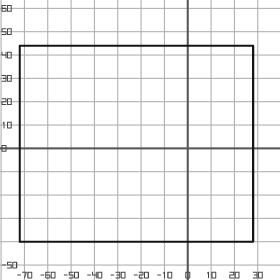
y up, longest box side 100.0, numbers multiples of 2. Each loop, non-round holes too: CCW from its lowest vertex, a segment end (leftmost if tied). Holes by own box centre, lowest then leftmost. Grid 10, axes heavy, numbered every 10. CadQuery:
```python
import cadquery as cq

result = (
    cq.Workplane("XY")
    .moveTo(-72.0, -40.0)
    .lineTo(28.0, -40.0)
    .lineTo(28.0, 44.0)
    .lineTo(-72.0, 44.0)
    .close()
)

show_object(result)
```